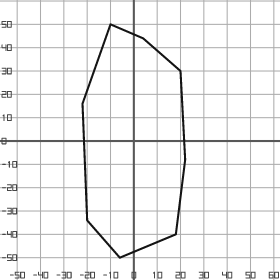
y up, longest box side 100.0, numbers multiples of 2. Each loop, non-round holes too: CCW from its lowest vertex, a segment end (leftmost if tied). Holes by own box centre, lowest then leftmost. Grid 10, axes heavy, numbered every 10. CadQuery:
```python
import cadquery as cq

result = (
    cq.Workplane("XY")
    .moveTo(-6.0, -50.0)
    .lineTo(18.0, -40.0)
    .lineTo(22.0, -8.0)
    .lineTo(20.0, 30.0)
    .lineTo(4.0, 44.0)
    .lineTo(-10.0, 50.0)
    .lineTo(-22.0, 16.0)
    .lineTo(-20.0, -34.0)
    .close()
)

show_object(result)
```